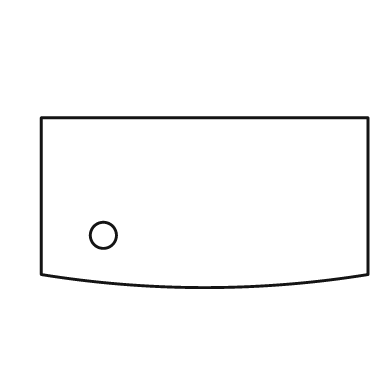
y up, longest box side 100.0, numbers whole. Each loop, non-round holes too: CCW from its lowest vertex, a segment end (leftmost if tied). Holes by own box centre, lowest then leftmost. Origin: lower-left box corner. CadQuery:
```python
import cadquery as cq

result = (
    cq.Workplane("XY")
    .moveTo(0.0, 4.0)
    .threePointArc((50.0, 0.0), (100.0, 4.0))
    .lineTo(100.0, 52.0)
    .lineTo(0.0, 52.0)
    .close()
    .moveTo(19.0, 16.0)
    .circle(4.0)
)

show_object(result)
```